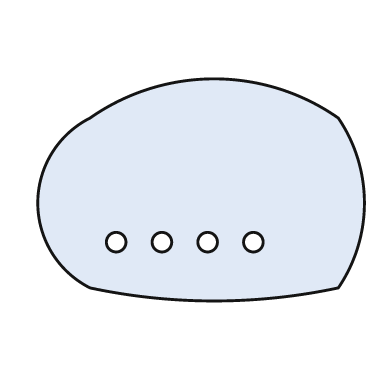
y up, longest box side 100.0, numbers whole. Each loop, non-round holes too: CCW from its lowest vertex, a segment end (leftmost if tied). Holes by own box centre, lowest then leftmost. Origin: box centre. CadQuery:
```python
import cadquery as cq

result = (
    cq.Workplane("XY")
    .moveTo(-34.0, -30.0)
    .threePointArc((4.0, -34.0), (42.0, -30.0))
    .threePointArc((50.0, -4.0), (42.0, 22.0))
    .threePointArc((4.0, 34.0), (-34.0, 22.0))
    .threePointArc((-50.0, -4.0), (-34.0, -30.0))
    .close()
    .moveTo(-26.0, -16.0)
    .circle(3.0)
    .moveTo(-12.0, -16.0)
    .circle(3.0)
    .moveTo(2.0, -16.0)
    .circle(3.0)
    .moveTo(16.0, -16.0)
    .circle(3.0)
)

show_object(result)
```